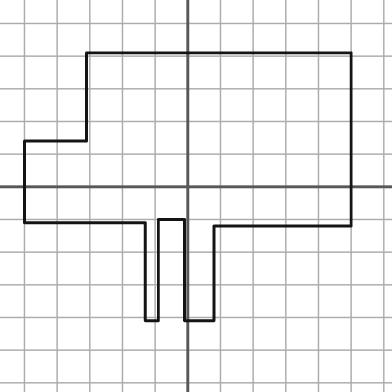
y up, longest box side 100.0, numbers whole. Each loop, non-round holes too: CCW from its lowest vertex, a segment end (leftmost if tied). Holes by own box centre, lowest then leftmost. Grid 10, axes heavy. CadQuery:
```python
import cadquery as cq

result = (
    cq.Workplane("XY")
    .moveTo(-13.0, -41.0)
    .lineTo(-9.0, -41.0)
    .lineTo(-9.0, -10.0)
    .lineTo(-1.0, -10.0)
    .lineTo(-1.0, -41.0)
    .lineTo(8.0, -41.0)
    .lineTo(8.0, -12.0)
    .lineTo(50.0, -12.0)
    .lineTo(50.0, 41.0)
    .lineTo(-31.0, 41.0)
    .lineTo(-31.0, 14.0)
    .lineTo(-50.0, 14.0)
    .lineTo(-50.0, -11.0)
    .lineTo(-13.0, -11.0)
    .close()
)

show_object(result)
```